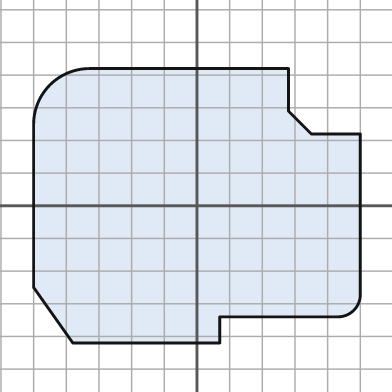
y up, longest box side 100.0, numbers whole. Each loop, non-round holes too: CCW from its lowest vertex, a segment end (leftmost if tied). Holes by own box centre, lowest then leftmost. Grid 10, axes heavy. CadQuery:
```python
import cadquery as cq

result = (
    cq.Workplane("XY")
    .moveTo(-38.0, -42.0)
    .lineTo(7.0, -42.0)
    .lineTo(7.0, -34.0)
    .lineTo(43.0, -34.0)
    .threePointArc((48.0, -32.0), (50.0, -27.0))
    .lineTo(50.0, 22.0)
    .lineTo(35.0, 22.0)
    .lineTo(28.0, 29.0)
    .lineTo(28.0, 42.0)
    .lineTo(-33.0, 42.0)
    .threePointArc((-45.0, 37.0), (-50.0, 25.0))
    .lineTo(-50.0, -25.0)
    .close()
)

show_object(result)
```